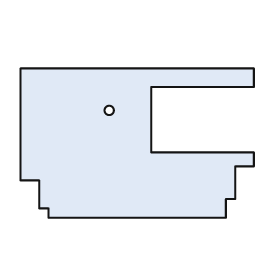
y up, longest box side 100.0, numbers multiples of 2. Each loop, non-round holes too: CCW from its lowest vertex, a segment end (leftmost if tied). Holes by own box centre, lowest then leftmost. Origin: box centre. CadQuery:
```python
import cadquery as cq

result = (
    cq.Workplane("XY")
    .moveTo(-38.0, -32.0)
    .lineTo(38.0, -32.0)
    .lineTo(38.0, -24.0)
    .lineTo(42.0, -24.0)
    .lineTo(42.0, -10.0)
    .lineTo(50.0, -10.0)
    .lineTo(50.0, -4.0)
    .lineTo(6.0, -4.0)
    .lineTo(6.0, 24.0)
    .lineTo(50.0, 24.0)
    .lineTo(50.0, 32.0)
    .lineTo(-50.0, 32.0)
    .lineTo(-50.0, -16.0)
    .lineTo(-42.0, -16.0)
    .lineTo(-42.0, -28.0)
    .lineTo(-38.0, -28.0)
    .close()
    .moveTo(-12.0, 14.0)
    .circle(2.0)
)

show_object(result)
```